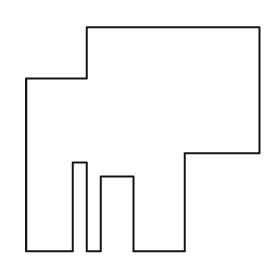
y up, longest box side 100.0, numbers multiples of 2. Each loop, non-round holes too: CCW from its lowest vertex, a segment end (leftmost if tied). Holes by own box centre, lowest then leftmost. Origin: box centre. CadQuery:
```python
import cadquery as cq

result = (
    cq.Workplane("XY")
    .moveTo(-50.0, -48.0)
    .lineTo(-30.0, -48.0)
    .lineTo(-30.0, -10.0)
    .lineTo(-24.0, -10.0)
    .lineTo(-24.0, -48.0)
    .lineTo(-18.0, -48.0)
    .lineTo(-18.0, -16.0)
    .lineTo(-4.0, -16.0)
    .lineTo(-4.0, -48.0)
    .lineTo(18.0, -48.0)
    .lineTo(18.0, -6.0)
    .lineTo(50.0, -6.0)
    .lineTo(50.0, 48.0)
    .lineTo(-24.0, 48.0)
    .lineTo(-24.0, 26.0)
    .lineTo(-50.0, 26.0)
    .close()
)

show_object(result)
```